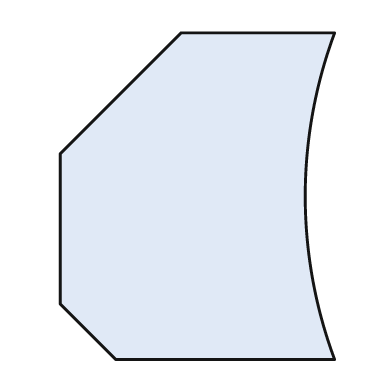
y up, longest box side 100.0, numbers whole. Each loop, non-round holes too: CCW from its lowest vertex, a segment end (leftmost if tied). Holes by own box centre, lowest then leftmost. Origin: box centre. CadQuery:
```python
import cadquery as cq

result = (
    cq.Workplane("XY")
    .moveTo(-25.0, -50.0)
    .lineTo(42.0, -50.0)
    .threePointArc((33.0, 0.0), (42.0, 50.0))
    .lineTo(-5.0, 50.0)
    .lineTo(-42.0, 13.0)
    .lineTo(-42.0, -33.0)
    .close()
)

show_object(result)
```